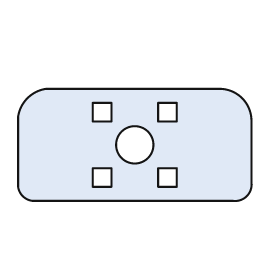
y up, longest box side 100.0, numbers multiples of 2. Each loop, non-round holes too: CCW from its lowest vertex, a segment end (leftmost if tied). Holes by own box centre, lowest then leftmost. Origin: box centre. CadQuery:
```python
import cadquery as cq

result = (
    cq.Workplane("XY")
    .moveTo(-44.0, -24.0)
    .lineTo(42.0, -24.0)
    .threePointArc((48.0, -22.0), (50.0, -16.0))
    .lineTo(50.0, 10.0)
    .threePointArc((46.0, 20.0), (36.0, 24.0))
    .lineTo(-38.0, 24.0)
    .threePointArc((-46.0, 20.0), (-50.0, 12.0))
    .lineTo(-50.0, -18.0)
    .threePointArc((-48.0, -22.0), (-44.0, -24.0))
    .close()
    .moveTo(-18.0, -18.0)
    .lineTo(-10.0, -18.0)
    .lineTo(-10.0, -10.0)
    .lineTo(-18.0, -10.0)
    .close()
    .moveTo(10.0, -18.0)
    .lineTo(18.0, -18.0)
    .lineTo(18.0, -10.0)
    .lineTo(10.0, -10.0)
    .close()
    .moveTo(0.0, 0.0)
    .circle(8.0)
    .moveTo(-18.0, 10.0)
    .lineTo(-10.0, 10.0)
    .lineTo(-10.0, 18.0)
    .lineTo(-18.0, 18.0)
    .close()
    .moveTo(10.0, 10.0)
    .lineTo(18.0, 10.0)
    .lineTo(18.0, 18.0)
    .lineTo(10.0, 18.0)
    .close()
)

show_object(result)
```